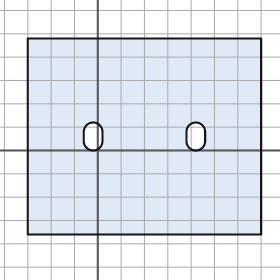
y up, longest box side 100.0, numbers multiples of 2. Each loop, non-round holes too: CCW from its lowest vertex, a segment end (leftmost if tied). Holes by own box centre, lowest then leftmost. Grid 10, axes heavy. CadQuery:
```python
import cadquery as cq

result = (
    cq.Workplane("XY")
    .moveTo(-30.0, -36.0)
    .lineTo(70.0, -36.0)
    .lineTo(70.0, 48.0)
    .lineTo(-30.0, 48.0)
    .close()
    .moveTo(-6.0, 4.0)
    .threePointArc((-2.0, 0.0), (2.0, 4.0))
    .lineTo(2.0, 8.0)
    .threePointArc((-2.0, 12.0), (-6.0, 8.0))
    .close()
    .moveTo(38.0, 4.0)
    .threePointArc((42.0, 0.0), (46.0, 4.0))
    .lineTo(46.0, 8.0)
    .threePointArc((42.0, 12.0), (38.0, 8.0))
    .close()
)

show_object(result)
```